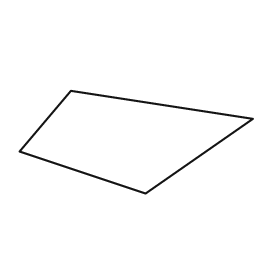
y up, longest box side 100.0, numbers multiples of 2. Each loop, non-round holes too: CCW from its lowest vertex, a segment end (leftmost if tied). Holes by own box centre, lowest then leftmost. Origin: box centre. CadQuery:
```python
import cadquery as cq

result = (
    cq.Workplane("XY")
    .moveTo(4.0, -22.0)
    .lineTo(50.0, 10.0)
    .lineTo(-28.0, 22.0)
    .lineTo(-50.0, -4.0)
    .close()
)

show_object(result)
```